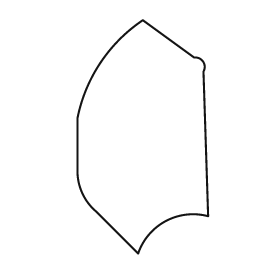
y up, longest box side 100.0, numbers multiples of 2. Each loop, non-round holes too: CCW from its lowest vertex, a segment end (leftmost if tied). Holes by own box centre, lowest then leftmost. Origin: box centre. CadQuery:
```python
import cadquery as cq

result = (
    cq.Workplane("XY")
    .moveTo(-2.0, -50.0)
    .threePointArc((10.0, -36.0), (28.0, -34.0))
    .lineTo(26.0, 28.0)
    .threePointArc((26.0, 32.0), (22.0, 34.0))
    .lineTo(0.0, 50.0)
    .threePointArc((-18.0, 32.0), (-28.0, 8.0))
    .lineTo(-28.0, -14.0)
    .threePointArc((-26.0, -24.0), (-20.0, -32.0))
    .close()
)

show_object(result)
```